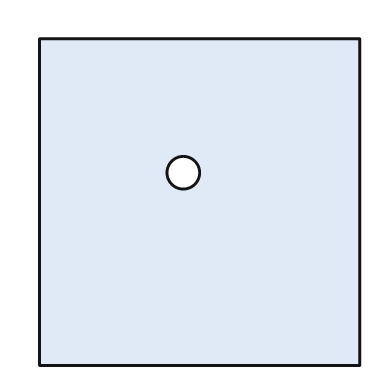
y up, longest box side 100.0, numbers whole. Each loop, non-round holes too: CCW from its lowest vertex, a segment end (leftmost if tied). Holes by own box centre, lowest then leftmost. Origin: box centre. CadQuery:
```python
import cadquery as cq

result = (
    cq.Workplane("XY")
    .moveTo(-49.0, -50.0)
    .lineTo(49.0, -50.0)
    .lineTo(49.0, 50.0)
    .lineTo(-49.0, 50.0)
    .close()
    .moveTo(-5.0, 9.0)
    .circle(5.0)
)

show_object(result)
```